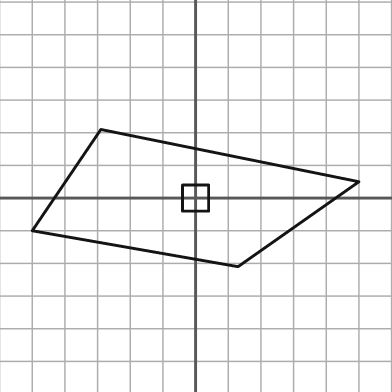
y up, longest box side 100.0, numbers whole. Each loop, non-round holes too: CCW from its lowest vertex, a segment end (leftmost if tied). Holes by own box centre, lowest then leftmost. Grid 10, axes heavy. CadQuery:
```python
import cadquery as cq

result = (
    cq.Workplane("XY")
    .moveTo(13.0, -21.0)
    .lineTo(50.0, 5.0)
    .lineTo(-29.0, 21.0)
    .lineTo(-50.0, -10.0)
    .close()
    .moveTo(-4.0, -4.0)
    .lineTo(4.0, -4.0)
    .lineTo(4.0, 4.0)
    .lineTo(-4.0, 4.0)
    .close()
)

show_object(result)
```